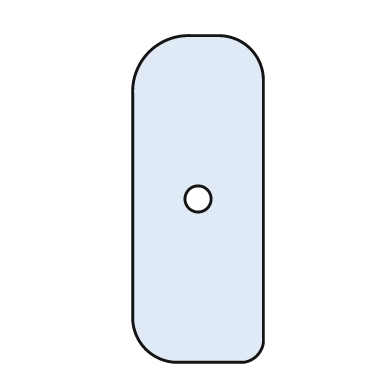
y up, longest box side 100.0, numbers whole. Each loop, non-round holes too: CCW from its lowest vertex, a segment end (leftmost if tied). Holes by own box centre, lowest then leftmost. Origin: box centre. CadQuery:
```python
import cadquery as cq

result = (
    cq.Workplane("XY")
    .moveTo(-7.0, -50.0)
    .lineTo(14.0, -50.0)
    .threePointArc((18.0, -48.0), (20.0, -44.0))
    .lineTo(20.0, 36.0)
    .threePointArc((16.0, 46.0), (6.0, 50.0))
    .lineTo(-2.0, 50.0)
    .threePointArc((-15.0, 45.0), (-20.0, 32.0))
    .lineTo(-20.0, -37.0)
    .threePointArc((-16.0, -46.0), (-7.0, -50.0))
    .close()
    .moveTo(0.0, 0.0)
    .circle(4.0)
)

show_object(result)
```